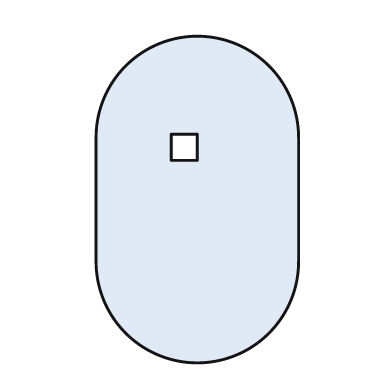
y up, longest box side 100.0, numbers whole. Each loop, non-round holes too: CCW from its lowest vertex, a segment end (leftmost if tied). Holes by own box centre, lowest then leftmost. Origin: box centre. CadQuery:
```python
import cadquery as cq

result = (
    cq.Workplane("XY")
    .moveTo(-31.0, -19.0)
    .threePointArc((0.0, -50.0), (31.0, -19.0))
    .lineTo(31.0, 19.0)
    .threePointArc((0.0, 50.0), (-31.0, 19.0))
    .close()
    .moveTo(-8.0, 12.0)
    .lineTo(0.0, 12.0)
    .lineTo(0.0, 20.0)
    .lineTo(-8.0, 20.0)
    .close()
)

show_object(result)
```